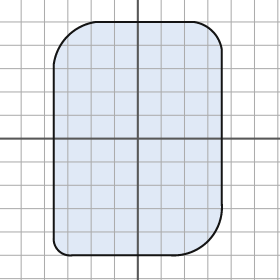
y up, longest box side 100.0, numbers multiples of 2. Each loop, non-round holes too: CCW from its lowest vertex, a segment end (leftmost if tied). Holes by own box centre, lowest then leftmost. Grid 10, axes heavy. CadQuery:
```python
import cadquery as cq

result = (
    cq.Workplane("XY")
    .moveTo(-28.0, -50.0)
    .lineTo(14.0, -50.0)
    .threePointArc((30.0, -44.0), (36.0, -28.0))
    .lineTo(36.0, 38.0)
    .threePointArc((32.0, 46.0), (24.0, 50.0))
    .lineTo(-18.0, 50.0)
    .threePointArc((-30.0, 44.0), (-36.0, 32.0))
    .lineTo(-36.0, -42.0)
    .threePointArc((-34.0, -48.0), (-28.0, -50.0))
    .close()
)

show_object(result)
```